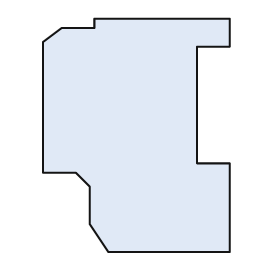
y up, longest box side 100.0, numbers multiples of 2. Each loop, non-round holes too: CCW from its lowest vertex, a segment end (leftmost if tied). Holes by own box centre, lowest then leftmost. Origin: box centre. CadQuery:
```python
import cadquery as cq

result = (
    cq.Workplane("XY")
    .moveTo(-12.0, -50.0)
    .lineTo(40.0, -50.0)
    .lineTo(40.0, -12.0)
    .lineTo(26.0, -12.0)
    .lineTo(26.0, 38.0)
    .lineTo(40.0, 38.0)
    .lineTo(40.0, 50.0)
    .lineTo(-18.0, 50.0)
    .lineTo(-18.0, 46.0)
    .lineTo(-32.0, 46.0)
    .lineTo(-40.0, 40.0)
    .lineTo(-40.0, -16.0)
    .lineTo(-26.0, -16.0)
    .lineTo(-20.0, -22.0)
    .lineTo(-20.0, -38.0)
    .close()
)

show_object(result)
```